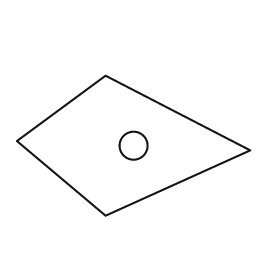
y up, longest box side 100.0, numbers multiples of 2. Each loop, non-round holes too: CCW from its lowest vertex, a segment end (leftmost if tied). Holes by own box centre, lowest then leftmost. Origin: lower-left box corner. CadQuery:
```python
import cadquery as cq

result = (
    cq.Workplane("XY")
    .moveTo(38.0, 0.0)
    .lineTo(100.0, 28.0)
    .lineTo(38.0, 60.0)
    .lineTo(0.0, 32.0)
    .close()
    .moveTo(50.0, 30.0)
    .circle(6.0)
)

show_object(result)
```